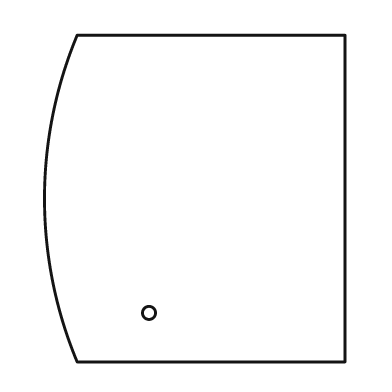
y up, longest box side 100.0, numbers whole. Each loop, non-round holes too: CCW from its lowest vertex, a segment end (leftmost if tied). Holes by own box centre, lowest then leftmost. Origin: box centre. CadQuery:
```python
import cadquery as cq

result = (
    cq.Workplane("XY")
    .moveTo(-36.0, -50.0)
    .lineTo(46.0, -50.0)
    .lineTo(46.0, 50.0)
    .lineTo(-36.0, 50.0)
    .threePointArc((-46.0, 0.0), (-36.0, -50.0))
    .close()
    .moveTo(-14.0, -35.0)
    .circle(2.0)
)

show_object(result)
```